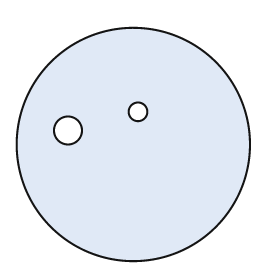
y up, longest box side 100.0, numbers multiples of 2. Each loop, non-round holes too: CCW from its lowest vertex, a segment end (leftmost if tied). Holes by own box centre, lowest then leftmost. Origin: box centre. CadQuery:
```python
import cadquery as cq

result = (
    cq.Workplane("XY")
    .moveTo(0.0, 0.0)
    .circle(50.0)
    .moveTo(-28.0, 6.0)
    .circle(6.0)
    .moveTo(2.0, 14.0)
    .circle(4.0)
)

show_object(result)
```